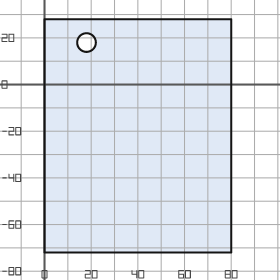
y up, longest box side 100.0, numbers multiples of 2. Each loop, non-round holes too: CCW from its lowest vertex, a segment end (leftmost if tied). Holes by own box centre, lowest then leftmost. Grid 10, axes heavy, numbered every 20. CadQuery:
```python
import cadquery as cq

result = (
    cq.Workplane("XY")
    .moveTo(0.0, -72.0)
    .lineTo(80.0, -72.0)
    .lineTo(80.0, 28.0)
    .lineTo(0.0, 28.0)
    .close()
    .moveTo(18.0, 18.0)
    .circle(4.0)
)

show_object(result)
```